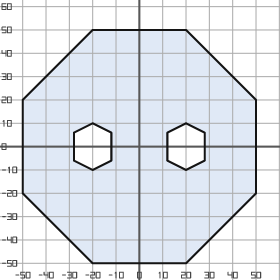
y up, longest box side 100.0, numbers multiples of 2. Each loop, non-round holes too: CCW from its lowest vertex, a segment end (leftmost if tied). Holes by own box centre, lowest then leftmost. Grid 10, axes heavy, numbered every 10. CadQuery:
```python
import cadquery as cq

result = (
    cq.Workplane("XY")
    .moveTo(-20.0, -50.0)
    .lineTo(20.0, -50.0)
    .lineTo(50.0, -20.0)
    .lineTo(50.0, 20.0)
    .lineTo(20.0, 50.0)
    .lineTo(-20.0, 50.0)
    .lineTo(-50.0, 20.0)
    .lineTo(-50.0, -20.0)
    .close()
    .moveTo(-20.0, -10.0)
    .lineTo(-12.0, -6.0)
    .lineTo(-12.0, 6.0)
    .lineTo(-20.0, 10.0)
    .lineTo(-28.0, 6.0)
    .lineTo(-28.0, -6.0)
    .close()
    .moveTo(20.0, -10.0)
    .lineTo(28.0, -6.0)
    .lineTo(28.0, 6.0)
    .lineTo(20.0, 10.0)
    .lineTo(12.0, 6.0)
    .lineTo(12.0, -6.0)
    .close()
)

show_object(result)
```